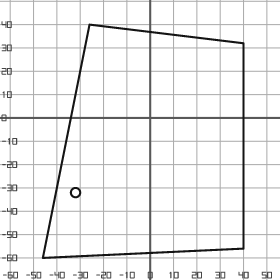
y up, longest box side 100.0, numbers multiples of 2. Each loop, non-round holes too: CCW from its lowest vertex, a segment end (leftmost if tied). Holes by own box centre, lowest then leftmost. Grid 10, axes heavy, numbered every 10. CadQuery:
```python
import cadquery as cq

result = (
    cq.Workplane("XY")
    .moveTo(-46.0, -60.0)
    .lineTo(40.0, -56.0)
    .lineTo(40.0, 32.0)
    .lineTo(-26.0, 40.0)
    .close()
    .moveTo(-32.0, -32.0)
    .circle(2.0)
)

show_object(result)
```